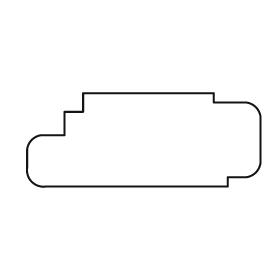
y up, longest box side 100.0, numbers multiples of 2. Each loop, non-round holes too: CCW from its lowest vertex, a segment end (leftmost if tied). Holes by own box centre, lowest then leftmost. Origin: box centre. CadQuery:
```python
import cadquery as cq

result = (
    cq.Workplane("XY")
    .moveTo(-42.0, -20.0)
    .lineTo(36.0, -20.0)
    .lineTo(36.0, -16.0)
    .lineTo(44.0, -16.0)
    .threePointArc((48.0, -14.0), (50.0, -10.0))
    .lineTo(50.0, 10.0)
    .threePointArc((48.0, 14.0), (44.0, 16.0))
    .lineTo(30.0, 16.0)
    .lineTo(30.0, 20.0)
    .lineTo(-26.0, 20.0)
    .lineTo(-26.0, 12.0)
    .lineTo(-34.0, 12.0)
    .lineTo(-34.0, 2.0)
    .lineTo(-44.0, 2.0)
    .threePointArc((-48.0, 0.0), (-50.0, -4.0))
    .lineTo(-50.0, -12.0)
    .threePointArc((-48.0, -18.0), (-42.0, -20.0))
    .close()
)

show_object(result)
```